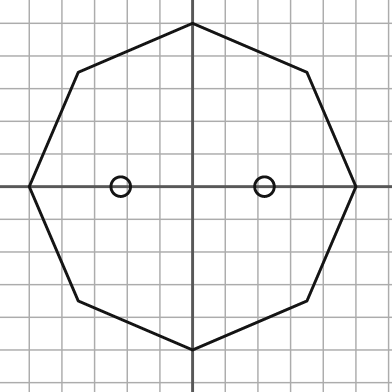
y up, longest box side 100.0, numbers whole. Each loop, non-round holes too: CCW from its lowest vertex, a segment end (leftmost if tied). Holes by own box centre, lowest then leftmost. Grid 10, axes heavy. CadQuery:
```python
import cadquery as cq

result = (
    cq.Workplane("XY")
    .moveTo(0.0, -50.0)
    .lineTo(35.0, -35.0)
    .lineTo(50.0, 0.0)
    .lineTo(35.0, 35.0)
    .lineTo(0.0, 50.0)
    .lineTo(-35.0, 35.0)
    .lineTo(-50.0, 0.0)
    .lineTo(-35.0, -35.0)
    .close()
    .moveTo(-22.0, 0.0)
    .circle(3.0)
    .moveTo(22.0, 0.0)
    .circle(3.0)
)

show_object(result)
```